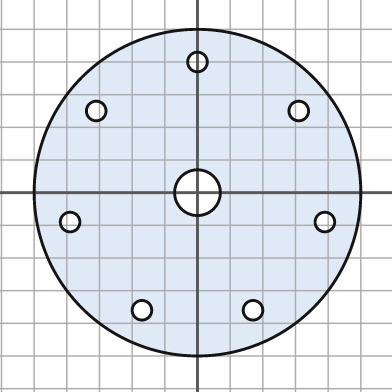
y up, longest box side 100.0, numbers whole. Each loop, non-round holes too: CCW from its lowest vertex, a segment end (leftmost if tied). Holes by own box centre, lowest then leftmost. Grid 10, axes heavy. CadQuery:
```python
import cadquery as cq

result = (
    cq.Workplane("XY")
    .moveTo(0.0, 0.0)
    .circle(50.0)
    .moveTo(-17.0, -36.0)
    .circle(3.0)
    .moveTo(17.0, -36.0)
    .circle(3.0)
    .moveTo(-39.0, -9.0)
    .circle(3.0)
    .moveTo(39.0, -9.0)
    .circle(3.0)
    .moveTo(0.0, 0.0)
    .circle(7.0)
    .moveTo(-31.0, 25.0)
    .circle(3.0)
    .moveTo(31.0, 25.0)
    .circle(3.0)
    .moveTo(0.0, 40.0)
    .circle(3.0)
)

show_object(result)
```